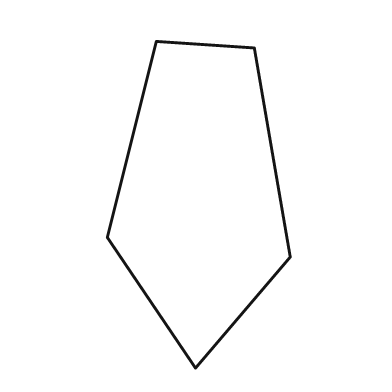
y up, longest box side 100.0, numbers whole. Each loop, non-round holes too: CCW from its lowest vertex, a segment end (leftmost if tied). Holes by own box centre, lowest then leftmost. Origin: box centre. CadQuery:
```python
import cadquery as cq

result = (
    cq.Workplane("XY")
    .moveTo(-1.0, -50.0)
    .lineTo(28.0, -16.0)
    .lineTo(17.0, 48.0)
    .lineTo(-13.0, 50.0)
    .lineTo(-28.0, -10.0)
    .close()
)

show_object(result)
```